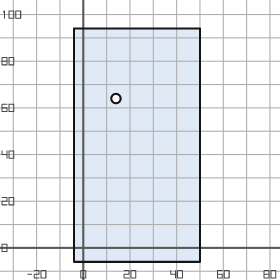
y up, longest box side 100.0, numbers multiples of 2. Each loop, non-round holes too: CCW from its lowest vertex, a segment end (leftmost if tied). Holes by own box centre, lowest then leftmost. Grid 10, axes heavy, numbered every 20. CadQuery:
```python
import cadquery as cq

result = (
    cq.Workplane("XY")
    .moveTo(-4.0, -6.0)
    .lineTo(50.0, -6.0)
    .lineTo(50.0, 94.0)
    .lineTo(-4.0, 94.0)
    .close()
    .moveTo(14.0, 64.0)
    .circle(2.0)
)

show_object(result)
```